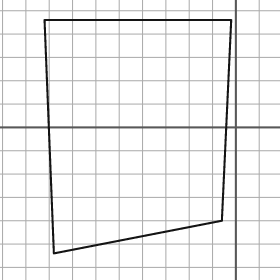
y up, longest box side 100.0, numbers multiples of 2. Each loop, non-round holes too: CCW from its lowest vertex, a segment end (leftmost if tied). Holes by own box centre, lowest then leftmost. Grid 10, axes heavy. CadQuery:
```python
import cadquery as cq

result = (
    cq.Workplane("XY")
    .moveTo(-78.0, -54.0)
    .lineTo(-6.0, -40.0)
    .lineTo(-2.0, 46.0)
    .lineTo(-82.0, 46.0)
    .close()
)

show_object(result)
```